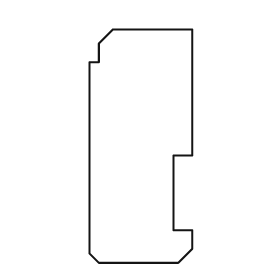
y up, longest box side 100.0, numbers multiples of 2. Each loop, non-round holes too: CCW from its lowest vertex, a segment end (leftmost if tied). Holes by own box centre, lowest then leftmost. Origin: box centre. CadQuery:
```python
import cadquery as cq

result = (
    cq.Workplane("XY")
    .moveTo(-18.0, -50.0)
    .lineTo(16.0, -50.0)
    .lineTo(22.0, -44.0)
    .lineTo(22.0, -36.0)
    .lineTo(14.0, -36.0)
    .lineTo(14.0, -4.0)
    .lineTo(22.0, -4.0)
    .lineTo(22.0, 50.0)
    .lineTo(-12.0, 50.0)
    .lineTo(-18.0, 44.0)
    .lineTo(-18.0, 36.0)
    .lineTo(-22.0, 36.0)
    .lineTo(-22.0, -46.0)
    .close()
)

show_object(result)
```